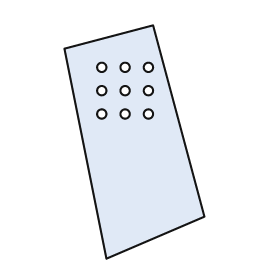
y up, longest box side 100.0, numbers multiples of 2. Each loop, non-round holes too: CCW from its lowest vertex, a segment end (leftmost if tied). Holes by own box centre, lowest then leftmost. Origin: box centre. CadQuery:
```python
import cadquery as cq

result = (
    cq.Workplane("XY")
    .moveTo(-12.0, -50.0)
    .lineTo(30.0, -32.0)
    .lineTo(8.0, 50.0)
    .lineTo(-30.0, 40.0)
    .close()
    .moveTo(-14.0, 12.0)
    .circle(2.0)
    .moveTo(-4.0, 12.0)
    .circle(2.0)
    .moveTo(6.0, 12.0)
    .circle(2.0)
    .moveTo(-14.0, 22.0)
    .circle(2.0)
    .moveTo(-4.0, 22.0)
    .circle(2.0)
    .moveTo(6.0, 22.0)
    .circle(2.0)
    .moveTo(-14.0, 32.0)
    .circle(2.0)
    .moveTo(-4.0, 32.0)
    .circle(2.0)
    .moveTo(6.0, 32.0)
    .circle(2.0)
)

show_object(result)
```